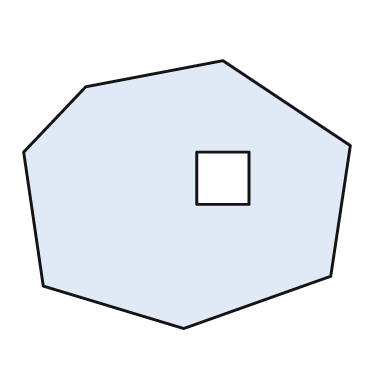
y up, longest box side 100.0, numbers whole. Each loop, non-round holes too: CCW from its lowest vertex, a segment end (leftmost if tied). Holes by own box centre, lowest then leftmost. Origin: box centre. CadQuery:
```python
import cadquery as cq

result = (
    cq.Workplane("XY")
    .moveTo(-1.0, -41.0)
    .lineTo(44.0, -25.0)
    .lineTo(50.0, 15.0)
    .lineTo(11.0, 41.0)
    .lineTo(-31.0, 33.0)
    .lineTo(-50.0, 13.0)
    .lineTo(-44.0, -28.0)
    .close()
    .moveTo(3.0, -3.0)
    .lineTo(19.0, -3.0)
    .lineTo(19.0, 13.0)
    .lineTo(3.0, 13.0)
    .close()
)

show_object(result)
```